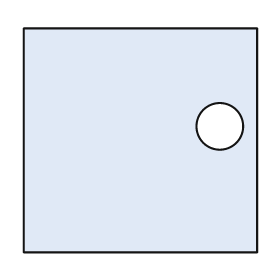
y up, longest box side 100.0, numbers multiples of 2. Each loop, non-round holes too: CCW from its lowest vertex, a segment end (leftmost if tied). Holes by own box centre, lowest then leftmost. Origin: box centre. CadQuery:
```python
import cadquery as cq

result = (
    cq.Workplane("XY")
    .moveTo(-50.0, -48.0)
    .lineTo(50.0, -48.0)
    .lineTo(50.0, 48.0)
    .lineTo(-50.0, 48.0)
    .close()
    .moveTo(34.0, 6.0)
    .circle(10.0)
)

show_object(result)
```